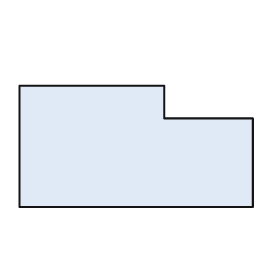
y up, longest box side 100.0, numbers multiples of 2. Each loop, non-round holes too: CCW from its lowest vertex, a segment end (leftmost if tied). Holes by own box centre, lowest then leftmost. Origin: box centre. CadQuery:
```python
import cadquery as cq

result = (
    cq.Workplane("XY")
    .moveTo(-50.0, -26.0)
    .lineTo(50.0, -26.0)
    .lineTo(50.0, 12.0)
    .lineTo(12.0, 12.0)
    .lineTo(12.0, 26.0)
    .lineTo(-50.0, 26.0)
    .close()
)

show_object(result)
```